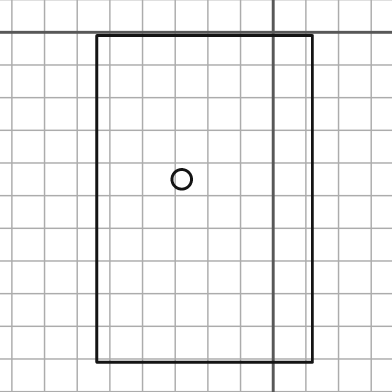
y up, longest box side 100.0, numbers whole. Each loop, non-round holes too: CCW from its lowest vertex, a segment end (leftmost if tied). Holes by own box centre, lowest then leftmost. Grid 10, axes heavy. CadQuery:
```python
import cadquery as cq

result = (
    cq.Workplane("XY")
    .moveTo(-54.0, -101.0)
    .lineTo(12.0, -101.0)
    .lineTo(12.0, -1.0)
    .lineTo(-54.0, -1.0)
    .close()
    .moveTo(-28.0, -45.0)
    .circle(3.0)
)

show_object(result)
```